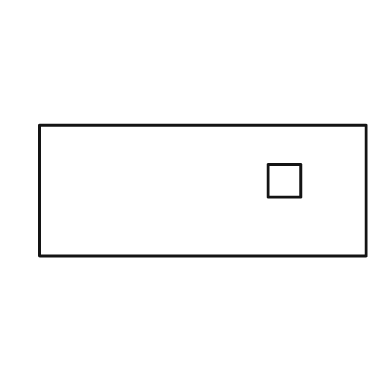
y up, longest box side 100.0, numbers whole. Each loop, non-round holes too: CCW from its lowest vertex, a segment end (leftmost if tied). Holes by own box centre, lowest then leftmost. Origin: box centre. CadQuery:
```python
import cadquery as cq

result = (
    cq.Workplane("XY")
    .moveTo(-50.0, -20.0)
    .lineTo(50.0, -20.0)
    .lineTo(50.0, 20.0)
    .lineTo(-50.0, 20.0)
    .close()
    .moveTo(20.0, -2.0)
    .lineTo(30.0, -2.0)
    .lineTo(30.0, 8.0)
    .lineTo(20.0, 8.0)
    .close()
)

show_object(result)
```